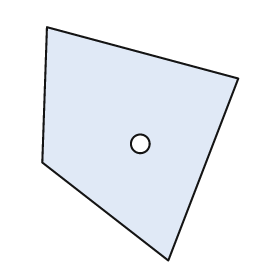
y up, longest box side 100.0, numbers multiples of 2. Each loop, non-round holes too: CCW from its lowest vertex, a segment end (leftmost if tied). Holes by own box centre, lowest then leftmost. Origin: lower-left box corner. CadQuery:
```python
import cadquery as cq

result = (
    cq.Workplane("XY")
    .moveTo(54.0, 0.0)
    .lineTo(84.0, 78.0)
    .lineTo(2.0, 100.0)
    .lineTo(0.0, 42.0)
    .close()
    .moveTo(42.0, 50.0)
    .circle(4.0)
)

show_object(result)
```